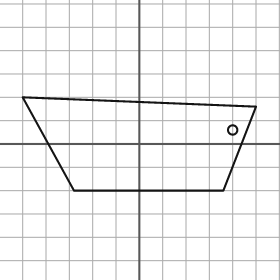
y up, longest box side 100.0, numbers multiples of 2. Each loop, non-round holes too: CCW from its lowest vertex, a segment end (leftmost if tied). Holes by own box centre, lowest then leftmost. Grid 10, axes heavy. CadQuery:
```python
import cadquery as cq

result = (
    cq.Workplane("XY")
    .moveTo(-28.0, -20.0)
    .lineTo(36.0, -20.0)
    .lineTo(50.0, 16.0)
    .lineTo(-50.0, 20.0)
    .close()
    .moveTo(40.0, 6.0)
    .circle(2.0)
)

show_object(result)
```